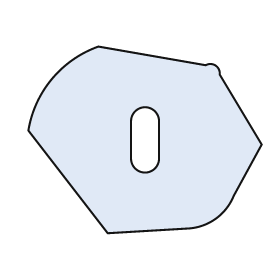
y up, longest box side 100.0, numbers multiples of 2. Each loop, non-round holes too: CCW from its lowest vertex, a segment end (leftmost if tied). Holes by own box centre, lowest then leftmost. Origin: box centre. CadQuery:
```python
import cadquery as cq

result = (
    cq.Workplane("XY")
    .moveTo(-16.0, -40.0)
    .lineTo(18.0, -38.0)
    .threePointArc((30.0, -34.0), (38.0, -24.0))
    .lineTo(50.0, -2.0)
    .lineTo(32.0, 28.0)
    .threePointArc((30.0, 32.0), (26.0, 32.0))
    .lineTo(-20.0, 40.0)
    .threePointArc((-40.0, 26.0), (-50.0, 4.0))
    .close()
    .moveTo(-6.0, -8.0)
    .threePointArc((0.0, -14.0), (6.0, -8.0))
    .lineTo(6.0, 8.0)
    .threePointArc((0.0, 14.0), (-6.0, 8.0))
    .close()
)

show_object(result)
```